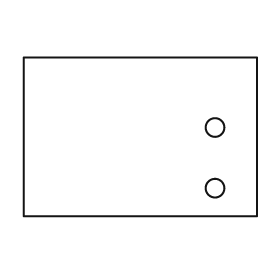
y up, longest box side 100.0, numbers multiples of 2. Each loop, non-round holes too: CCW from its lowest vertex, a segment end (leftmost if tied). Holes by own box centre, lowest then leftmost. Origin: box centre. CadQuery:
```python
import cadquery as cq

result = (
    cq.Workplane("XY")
    .moveTo(-50.0, -34.0)
    .lineTo(50.0, -34.0)
    .lineTo(50.0, 34.0)
    .lineTo(-50.0, 34.0)
    .close()
    .moveTo(32.0, -22.0)
    .circle(4.0)
    .moveTo(32.0, 4.0)
    .circle(4.0)
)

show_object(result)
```